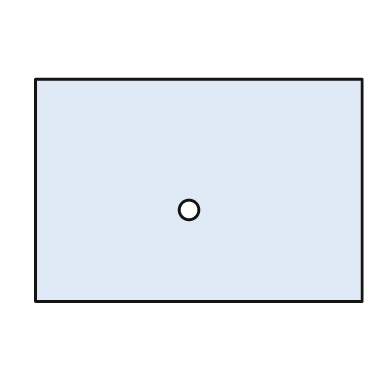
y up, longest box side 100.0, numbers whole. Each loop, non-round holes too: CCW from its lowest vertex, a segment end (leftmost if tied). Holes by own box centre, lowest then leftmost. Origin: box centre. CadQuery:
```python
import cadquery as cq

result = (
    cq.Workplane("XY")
    .moveTo(-50.0, -34.0)
    .lineTo(50.0, -34.0)
    .lineTo(50.0, 34.0)
    .lineTo(-50.0, 34.0)
    .close()
    .moveTo(-3.0, -6.0)
    .circle(3.0)
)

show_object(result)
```